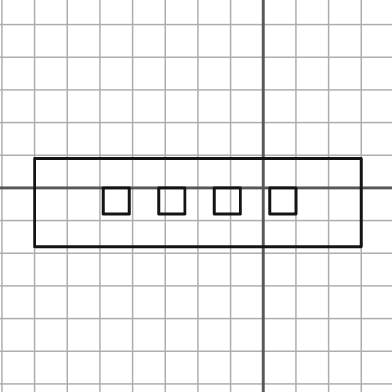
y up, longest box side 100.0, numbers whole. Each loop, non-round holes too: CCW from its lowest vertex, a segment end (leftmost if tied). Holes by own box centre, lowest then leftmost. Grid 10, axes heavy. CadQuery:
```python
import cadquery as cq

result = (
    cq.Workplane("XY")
    .moveTo(-70.0, -18.0)
    .lineTo(30.0, -18.0)
    .lineTo(30.0, 9.0)
    .lineTo(-70.0, 9.0)
    .close()
    .moveTo(-49.0, -8.0)
    .lineTo(-41.0, -8.0)
    .lineTo(-41.0, 0.0)
    .lineTo(-49.0, 0.0)
    .close()
    .moveTo(-32.0, -8.0)
    .lineTo(-24.0, -8.0)
    .lineTo(-24.0, 0.0)
    .lineTo(-32.0, 0.0)
    .close()
    .moveTo(-15.0, -8.0)
    .lineTo(-7.0, -8.0)
    .lineTo(-7.0, 0.0)
    .lineTo(-15.0, 0.0)
    .close()
    .moveTo(2.0, -8.0)
    .lineTo(10.0, -8.0)
    .lineTo(10.0, 0.0)
    .lineTo(2.0, 0.0)
    .close()
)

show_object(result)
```